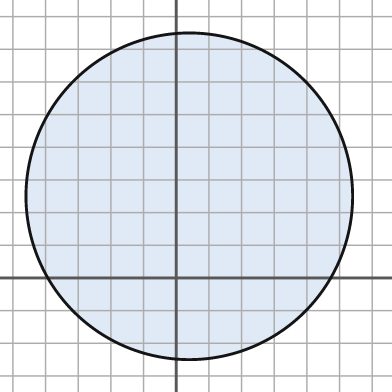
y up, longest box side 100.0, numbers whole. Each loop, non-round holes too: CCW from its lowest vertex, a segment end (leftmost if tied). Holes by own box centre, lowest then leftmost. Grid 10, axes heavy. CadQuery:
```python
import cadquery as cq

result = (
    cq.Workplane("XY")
    .moveTo(4.0, 25.0)
    .circle(50.0)
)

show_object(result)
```